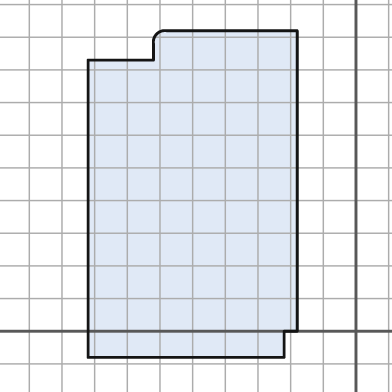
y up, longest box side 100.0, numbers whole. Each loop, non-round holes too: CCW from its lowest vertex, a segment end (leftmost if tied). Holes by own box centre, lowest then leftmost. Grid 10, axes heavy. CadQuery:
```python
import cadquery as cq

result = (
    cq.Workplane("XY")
    .moveTo(-82.0, -8.0)
    .lineTo(-22.0, -8.0)
    .lineTo(-22.0, 0.0)
    .lineTo(-18.0, 0.0)
    .lineTo(-18.0, 92.0)
    .lineTo(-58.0, 92.0)
    .threePointArc((-61.0, 91.0), (-62.0, 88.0))
    .lineTo(-62.0, 83.0)
    .lineTo(-82.0, 83.0)
    .close()
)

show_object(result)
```